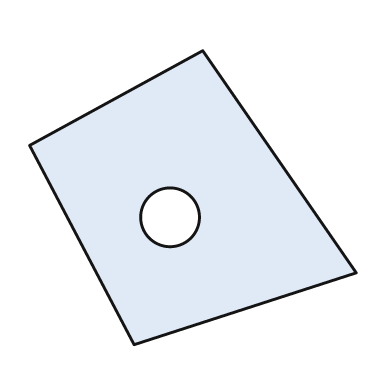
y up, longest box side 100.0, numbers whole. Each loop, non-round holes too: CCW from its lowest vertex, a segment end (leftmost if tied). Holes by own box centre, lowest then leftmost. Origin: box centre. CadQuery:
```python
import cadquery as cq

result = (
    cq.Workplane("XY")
    .moveTo(-18.0, -45.0)
    .lineTo(50.0, -23.0)
    .lineTo(3.0, 45.0)
    .lineTo(-50.0, 16.0)
    .close()
    .moveTo(-7.0, -6.0)
    .circle(9.0)
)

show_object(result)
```